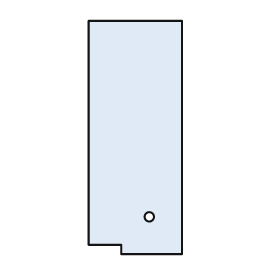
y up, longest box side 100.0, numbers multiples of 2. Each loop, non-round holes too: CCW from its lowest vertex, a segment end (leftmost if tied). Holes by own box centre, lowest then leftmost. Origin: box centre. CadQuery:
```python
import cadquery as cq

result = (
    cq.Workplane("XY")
    .moveTo(-6.0, -50.0)
    .lineTo(20.0, -50.0)
    .lineTo(20.0, 50.0)
    .lineTo(-20.0, 50.0)
    .lineTo(-20.0, -46.0)
    .lineTo(-6.0, -46.0)
    .close()
    .moveTo(6.0, -34.0)
    .circle(2.0)
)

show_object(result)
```